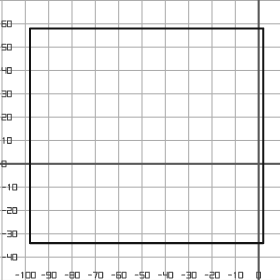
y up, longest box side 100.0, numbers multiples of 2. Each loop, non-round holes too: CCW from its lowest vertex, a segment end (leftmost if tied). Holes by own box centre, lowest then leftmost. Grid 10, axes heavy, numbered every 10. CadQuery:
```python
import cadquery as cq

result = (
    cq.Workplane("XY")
    .moveTo(-98.0, -34.0)
    .lineTo(2.0, -34.0)
    .lineTo(2.0, 58.0)
    .lineTo(-98.0, 58.0)
    .close()
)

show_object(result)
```